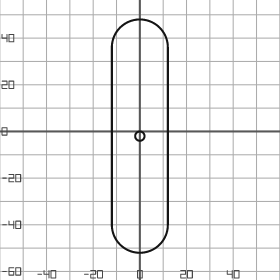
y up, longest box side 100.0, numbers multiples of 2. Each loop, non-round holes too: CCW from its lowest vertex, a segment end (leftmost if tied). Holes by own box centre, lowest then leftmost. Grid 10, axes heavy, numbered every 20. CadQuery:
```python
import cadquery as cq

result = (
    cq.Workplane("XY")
    .moveTo(-12.0, -40.0)
    .threePointArc((0.0, -52.0), (12.0, -40.0))
    .lineTo(12.0, 36.0)
    .threePointArc((0.0, 48.0), (-12.0, 36.0))
    .close()
    .moveTo(0.0, -2.0)
    .circle(2.0)
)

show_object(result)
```